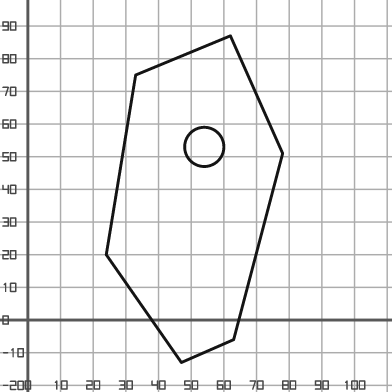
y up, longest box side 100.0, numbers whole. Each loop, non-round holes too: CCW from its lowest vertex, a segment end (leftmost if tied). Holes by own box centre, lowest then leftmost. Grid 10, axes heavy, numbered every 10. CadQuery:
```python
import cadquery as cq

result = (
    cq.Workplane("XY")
    .moveTo(47.0, -13.0)
    .lineTo(63.0, -6.0)
    .lineTo(78.0, 51.0)
    .lineTo(62.0, 87.0)
    .lineTo(33.0, 75.0)
    .lineTo(24.0, 20.0)
    .close()
    .moveTo(54.0, 53.0)
    .circle(6.0)
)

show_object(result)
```